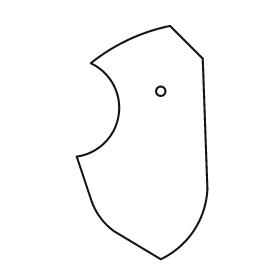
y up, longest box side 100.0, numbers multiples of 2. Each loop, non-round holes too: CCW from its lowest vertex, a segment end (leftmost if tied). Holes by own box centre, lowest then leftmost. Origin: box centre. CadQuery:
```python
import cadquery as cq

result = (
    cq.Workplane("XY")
    .moveTo(8.0, -50.0)
    .threePointArc((22.0, -38.0), (28.0, -20.0))
    .lineTo(26.0, 36.0)
    .lineTo(12.0, 50.0)
    .threePointArc((-6.0, 44.0), (-22.0, 34.0))
    .threePointArc((-10.0, 12.0), (-28.0, -6.0))
    .lineTo(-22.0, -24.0)
    .threePointArc((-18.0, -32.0), (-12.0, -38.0))
    .close()
    .moveTo(8.0, 22.0)
    .circle(2.0)
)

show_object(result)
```